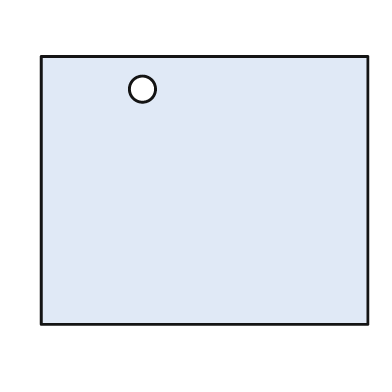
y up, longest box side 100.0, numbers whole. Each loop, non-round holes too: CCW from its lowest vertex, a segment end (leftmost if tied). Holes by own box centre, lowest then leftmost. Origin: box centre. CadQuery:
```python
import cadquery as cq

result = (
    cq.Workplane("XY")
    .moveTo(-50.0, -41.0)
    .lineTo(50.0, -41.0)
    .lineTo(50.0, 41.0)
    .lineTo(-50.0, 41.0)
    .close()
    .moveTo(-19.0, 31.0)
    .circle(4.0)
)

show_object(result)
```